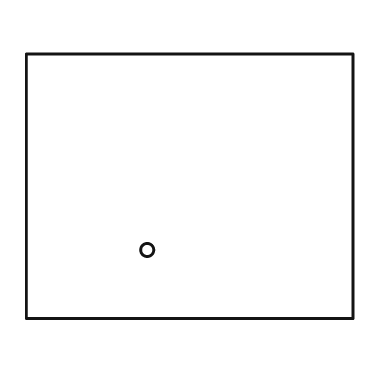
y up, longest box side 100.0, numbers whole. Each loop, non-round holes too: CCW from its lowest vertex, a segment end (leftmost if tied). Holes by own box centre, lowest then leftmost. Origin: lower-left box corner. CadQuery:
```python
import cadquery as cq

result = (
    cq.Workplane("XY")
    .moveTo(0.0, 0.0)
    .lineTo(100.0, 0.0)
    .lineTo(100.0, 81.0)
    .lineTo(0.0, 81.0)
    .close()
    .moveTo(37.0, 21.0)
    .circle(2.0)
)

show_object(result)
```